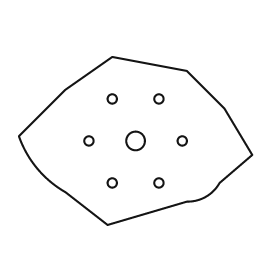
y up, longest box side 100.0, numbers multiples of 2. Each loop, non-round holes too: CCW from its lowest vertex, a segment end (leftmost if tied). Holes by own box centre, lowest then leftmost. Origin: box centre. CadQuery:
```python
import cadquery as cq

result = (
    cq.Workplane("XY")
    .moveTo(-12.0, -36.0)
    .lineTo(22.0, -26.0)
    .threePointArc((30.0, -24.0), (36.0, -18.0))
    .lineTo(50.0, -6.0)
    .lineTo(38.0, 14.0)
    .lineTo(22.0, 30.0)
    .lineTo(-10.0, 36.0)
    .lineTo(-30.0, 22.0)
    .lineTo(-50.0, 2.0)
    .threePointArc((-42.0, -12.0), (-30.0, -22.0))
    .close()
    .moveTo(-10.0, -18.0)
    .circle(2.0)
    .moveTo(10.0, -18.0)
    .circle(2.0)
    .moveTo(-20.0, 0.0)
    .circle(2.0)
    .moveTo(0.0, 0.0)
    .circle(4.0)
    .moveTo(20.0, 0.0)
    .circle(2.0)
    .moveTo(-10.0, 18.0)
    .circle(2.0)
    .moveTo(10.0, 18.0)
    .circle(2.0)
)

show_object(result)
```